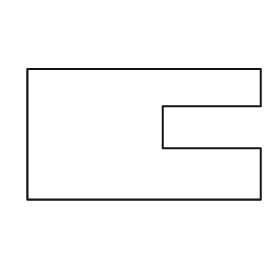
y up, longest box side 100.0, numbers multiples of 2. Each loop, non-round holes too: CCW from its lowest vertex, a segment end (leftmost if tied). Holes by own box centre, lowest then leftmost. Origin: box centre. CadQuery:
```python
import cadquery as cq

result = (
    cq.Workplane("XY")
    .moveTo(-50.0, -28.0)
    .lineTo(50.0, -28.0)
    .lineTo(50.0, -6.0)
    .lineTo(8.0, -6.0)
    .lineTo(8.0, 12.0)
    .lineTo(50.0, 12.0)
    .lineTo(50.0, 28.0)
    .lineTo(-50.0, 28.0)
    .close()
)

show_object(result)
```